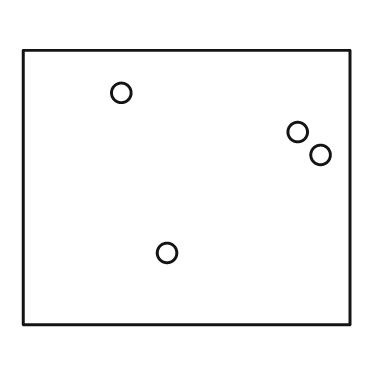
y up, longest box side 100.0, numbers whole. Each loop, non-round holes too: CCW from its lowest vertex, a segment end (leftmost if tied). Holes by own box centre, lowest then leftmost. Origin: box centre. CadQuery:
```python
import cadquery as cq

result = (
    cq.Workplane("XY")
    .moveTo(-50.0, -42.0)
    .lineTo(50.0, -42.0)
    .lineTo(50.0, 42.0)
    .lineTo(-50.0, 42.0)
    .close()
    .moveTo(-6.0, -20.0)
    .circle(3.0)
    .moveTo(41.0, 10.0)
    .circle(3.0)
    .moveTo(34.0, 17.0)
    .circle(3.0)
    .moveTo(-20.0, 29.0)
    .circle(3.0)
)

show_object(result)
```